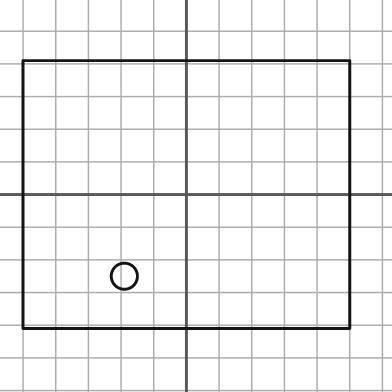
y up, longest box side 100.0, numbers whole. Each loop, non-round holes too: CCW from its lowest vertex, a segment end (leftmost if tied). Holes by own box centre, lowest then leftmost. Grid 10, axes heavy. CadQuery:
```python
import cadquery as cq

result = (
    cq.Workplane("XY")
    .moveTo(-50.0, -41.0)
    .lineTo(50.0, -41.0)
    .lineTo(50.0, 41.0)
    .lineTo(-50.0, 41.0)
    .close()
    .moveTo(-19.0, -25.0)
    .circle(4.0)
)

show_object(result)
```